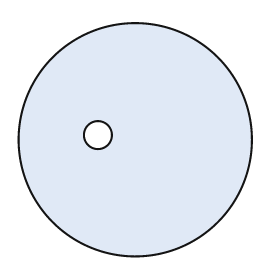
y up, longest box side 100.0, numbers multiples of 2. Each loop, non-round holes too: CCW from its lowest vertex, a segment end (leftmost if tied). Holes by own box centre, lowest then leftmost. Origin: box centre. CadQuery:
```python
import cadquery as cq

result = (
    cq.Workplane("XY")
    .moveTo(0.0, 0.0)
    .circle(50.0)
    .moveTo(-16.0, 2.0)
    .circle(6.0)
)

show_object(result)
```